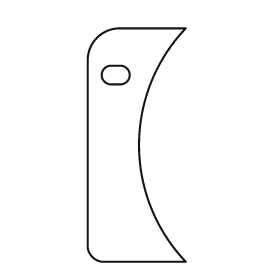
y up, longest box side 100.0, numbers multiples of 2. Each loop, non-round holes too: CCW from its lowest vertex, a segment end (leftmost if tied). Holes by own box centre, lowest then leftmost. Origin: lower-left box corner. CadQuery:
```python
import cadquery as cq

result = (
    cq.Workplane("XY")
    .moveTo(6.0, 0.0)
    .lineTo(42.0, 0.0)
    .threePointArc((22.0, 50.0), (42.0, 100.0))
    .lineTo(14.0, 100.0)
    .threePointArc((4.0, 96.0), (0.0, 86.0))
    .lineTo(0.0, 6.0)
    .threePointArc((2.0, 2.0), (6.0, 0.0))
    .close()
    .moveTo(10.0, 76.0)
    .lineTo(14.0, 76.0)
    .threePointArc((18.0, 80.0), (14.0, 84.0))
    .lineTo(10.0, 84.0)
    .threePointArc((6.0, 80.0), (10.0, 76.0))
    .close()
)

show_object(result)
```